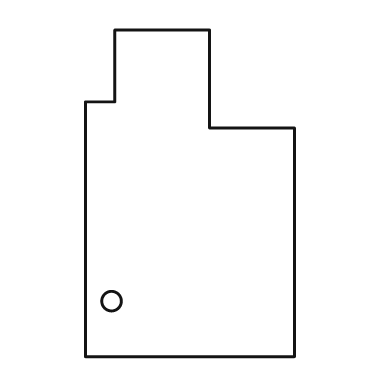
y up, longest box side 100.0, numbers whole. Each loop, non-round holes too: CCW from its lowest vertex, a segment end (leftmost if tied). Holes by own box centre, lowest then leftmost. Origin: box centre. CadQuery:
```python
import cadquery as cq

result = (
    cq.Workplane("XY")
    .moveTo(-32.0, -50.0)
    .lineTo(32.0, -50.0)
    .lineTo(32.0, 20.0)
    .lineTo(6.0, 20.0)
    .lineTo(6.0, 50.0)
    .lineTo(-23.0, 50.0)
    .lineTo(-23.0, 28.0)
    .lineTo(-32.0, 28.0)
    .close()
    .moveTo(-24.0, -33.0)
    .circle(3.0)
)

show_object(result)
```